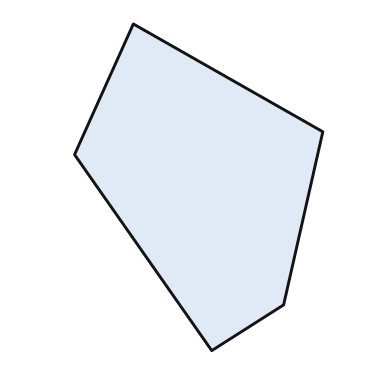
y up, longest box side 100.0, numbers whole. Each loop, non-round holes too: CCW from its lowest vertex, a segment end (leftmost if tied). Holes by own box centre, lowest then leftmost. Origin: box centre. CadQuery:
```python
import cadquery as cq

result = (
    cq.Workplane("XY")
    .moveTo(4.0, -50.0)
    .lineTo(26.0, -36.0)
    .lineTo(38.0, 17.0)
    .lineTo(-20.0, 50.0)
    .lineTo(-38.0, 10.0)
    .close()
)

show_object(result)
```